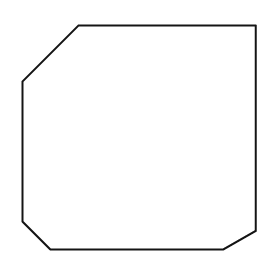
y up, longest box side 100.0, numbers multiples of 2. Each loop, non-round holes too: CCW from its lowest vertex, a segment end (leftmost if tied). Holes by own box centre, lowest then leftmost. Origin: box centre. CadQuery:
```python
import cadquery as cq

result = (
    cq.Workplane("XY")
    .moveTo(-38.0, -48.0)
    .lineTo(36.0, -48.0)
    .lineTo(50.0, -40.0)
    .lineTo(50.0, 48.0)
    .lineTo(-26.0, 48.0)
    .lineTo(-50.0, 24.0)
    .lineTo(-50.0, -36.0)
    .close()
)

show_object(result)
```